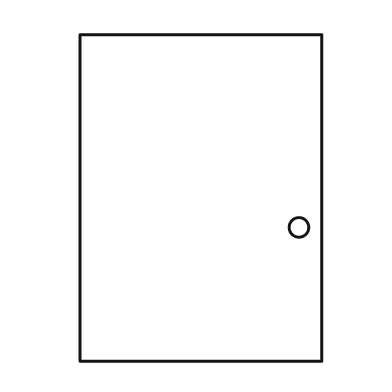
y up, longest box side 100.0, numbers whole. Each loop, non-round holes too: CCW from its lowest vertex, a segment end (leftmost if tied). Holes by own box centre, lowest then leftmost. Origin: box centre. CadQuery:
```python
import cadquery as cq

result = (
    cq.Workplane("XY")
    .moveTo(-37.0, -50.0)
    .lineTo(37.0, -50.0)
    .lineTo(37.0, 50.0)
    .lineTo(-37.0, 50.0)
    .close()
    .moveTo(30.0, -9.0)
    .circle(3.0)
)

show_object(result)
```